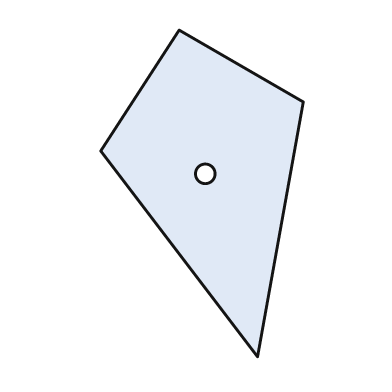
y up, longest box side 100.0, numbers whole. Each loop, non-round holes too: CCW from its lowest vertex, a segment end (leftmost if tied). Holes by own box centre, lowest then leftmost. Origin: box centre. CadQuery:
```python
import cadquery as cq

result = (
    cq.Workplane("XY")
    .moveTo(17.0, -50.0)
    .lineTo(31.0, 28.0)
    .lineTo(-7.0, 50.0)
    .lineTo(-31.0, 13.0)
    .close()
    .moveTo(1.0, 6.0)
    .circle(3.0)
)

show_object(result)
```